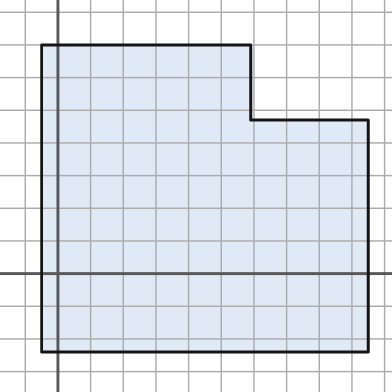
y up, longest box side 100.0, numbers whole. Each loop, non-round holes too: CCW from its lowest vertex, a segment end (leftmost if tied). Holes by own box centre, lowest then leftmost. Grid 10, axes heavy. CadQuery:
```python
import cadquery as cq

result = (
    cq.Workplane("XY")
    .moveTo(-5.0, -24.0)
    .lineTo(95.0, -24.0)
    .lineTo(95.0, 47.0)
    .lineTo(59.0, 47.0)
    .lineTo(59.0, 70.0)
    .lineTo(-5.0, 70.0)
    .close()
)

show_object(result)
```